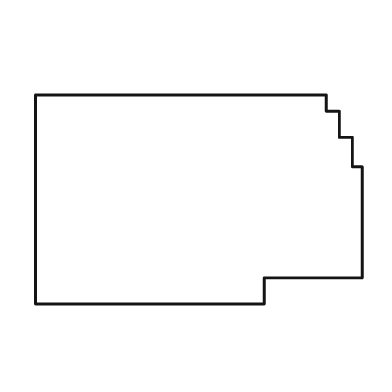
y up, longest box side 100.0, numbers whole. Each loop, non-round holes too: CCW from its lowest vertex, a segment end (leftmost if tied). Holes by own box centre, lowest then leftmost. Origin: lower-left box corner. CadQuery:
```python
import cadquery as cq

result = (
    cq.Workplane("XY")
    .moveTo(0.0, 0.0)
    .lineTo(70.0, 0.0)
    .lineTo(70.0, 8.0)
    .lineTo(100.0, 8.0)
    .lineTo(100.0, 42.0)
    .lineTo(97.0, 42.0)
    .lineTo(97.0, 51.0)
    .lineTo(93.0, 51.0)
    .lineTo(93.0, 59.0)
    .lineTo(89.0, 59.0)
    .lineTo(89.0, 64.0)
    .lineTo(0.0, 64.0)
    .close()
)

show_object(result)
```